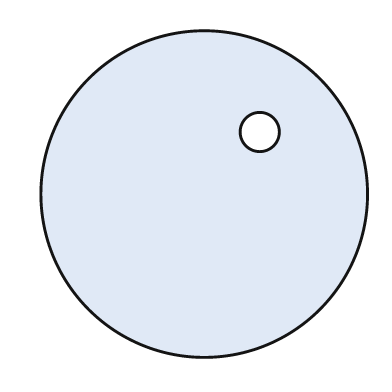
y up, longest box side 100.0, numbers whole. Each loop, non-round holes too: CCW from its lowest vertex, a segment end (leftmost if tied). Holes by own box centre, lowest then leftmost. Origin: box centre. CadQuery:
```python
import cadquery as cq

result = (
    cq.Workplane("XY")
    .moveTo(0.0, 0.0)
    .circle(50.0)
    .moveTo(17.0, 19.0)
    .circle(6.0)
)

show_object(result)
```